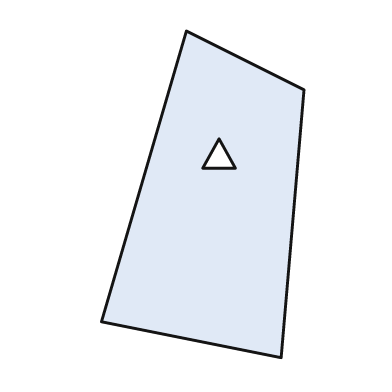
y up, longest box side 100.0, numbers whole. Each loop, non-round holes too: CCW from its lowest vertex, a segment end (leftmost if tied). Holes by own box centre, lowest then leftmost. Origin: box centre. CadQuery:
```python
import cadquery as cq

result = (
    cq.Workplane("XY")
    .moveTo(24.0, -50.0)
    .lineTo(31.0, 32.0)
    .lineTo(-5.0, 50.0)
    .lineTo(-31.0, -39.0)
    .close()
    .moveTo(0.0, 8.0)
    .lineTo(10.0, 8.0)
    .lineTo(5.0, 17.0)
    .close()
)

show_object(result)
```